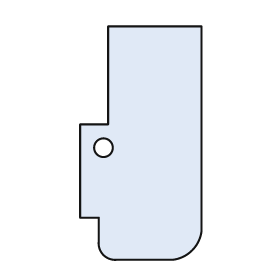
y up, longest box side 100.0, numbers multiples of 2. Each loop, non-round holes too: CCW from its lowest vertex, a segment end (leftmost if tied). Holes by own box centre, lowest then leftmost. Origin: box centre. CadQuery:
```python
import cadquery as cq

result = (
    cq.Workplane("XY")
    .moveTo(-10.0, -50.0)
    .lineTo(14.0, -50.0)
    .threePointArc((22.0, -46.0), (26.0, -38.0))
    .lineTo(26.0, 50.0)
    .lineTo(-14.0, 50.0)
    .lineTo(-14.0, 8.0)
    .lineTo(-26.0, 8.0)
    .lineTo(-26.0, -32.0)
    .lineTo(-18.0, -32.0)
    .lineTo(-18.0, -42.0)
    .threePointArc((-16.0, -48.0), (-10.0, -50.0))
    .close()
    .moveTo(-16.0, -2.0)
    .circle(4.0)
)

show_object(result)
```